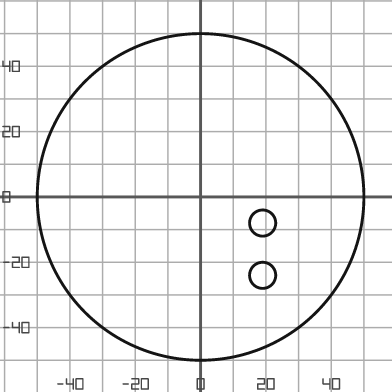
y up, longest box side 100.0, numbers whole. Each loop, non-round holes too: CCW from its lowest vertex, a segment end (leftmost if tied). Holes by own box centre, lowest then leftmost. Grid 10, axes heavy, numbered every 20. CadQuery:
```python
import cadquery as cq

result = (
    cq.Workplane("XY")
    .moveTo(0.0, 0.0)
    .circle(50.0)
    .moveTo(19.0, -24.0)
    .circle(4.0)
    .moveTo(19.0, -8.0)
    .circle(4.0)
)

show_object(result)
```